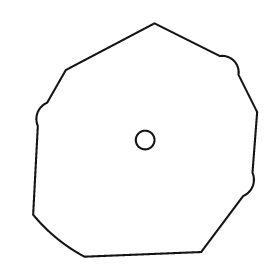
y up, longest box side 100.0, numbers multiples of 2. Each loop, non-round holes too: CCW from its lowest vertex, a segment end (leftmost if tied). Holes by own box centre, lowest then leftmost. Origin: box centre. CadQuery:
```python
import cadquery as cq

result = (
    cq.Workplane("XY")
    .moveTo(-26.0, -50.0)
    .lineTo(24.0, -48.0)
    .lineTo(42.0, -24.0)
    .threePointArc((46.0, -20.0), (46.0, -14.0))
    .lineTo(48.0, 12.0)
    .lineTo(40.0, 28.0)
    .threePointArc((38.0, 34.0), (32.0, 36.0))
    .lineTo(4.0, 50.0)
    .lineTo(-34.0, 30.0)
    .lineTo(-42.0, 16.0)
    .threePointArc((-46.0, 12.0), (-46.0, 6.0))
    .lineTo(-48.0, -32.0)
    .threePointArc((-38.0, -42.0), (-26.0, -50.0))
    .close()
    .moveTo(0.0, 0.0)
    .circle(4.0)
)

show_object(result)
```